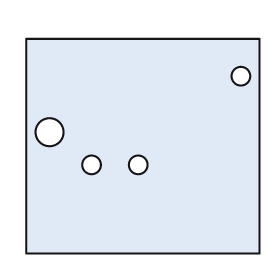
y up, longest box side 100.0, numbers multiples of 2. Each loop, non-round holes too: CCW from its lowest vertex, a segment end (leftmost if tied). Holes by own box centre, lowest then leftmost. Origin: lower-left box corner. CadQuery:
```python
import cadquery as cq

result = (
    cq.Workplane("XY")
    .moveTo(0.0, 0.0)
    .lineTo(100.0, 0.0)
    .lineTo(100.0, 92.0)
    .lineTo(0.0, 92.0)
    .close()
    .moveTo(28.0, 38.0)
    .circle(4.0)
    .moveTo(48.0, 38.0)
    .circle(4.0)
    .moveTo(10.0, 52.0)
    .circle(6.0)
    .moveTo(92.0, 76.0)
    .circle(4.0)
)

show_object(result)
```